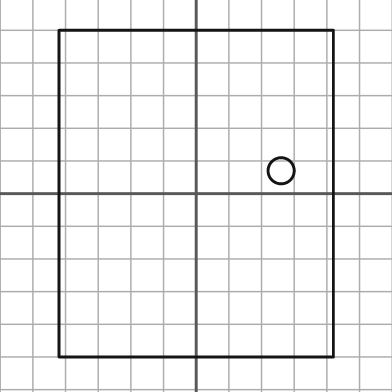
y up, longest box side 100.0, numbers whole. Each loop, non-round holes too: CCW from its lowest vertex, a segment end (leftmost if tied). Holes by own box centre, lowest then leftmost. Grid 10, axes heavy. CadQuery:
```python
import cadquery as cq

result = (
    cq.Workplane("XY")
    .moveTo(-42.0, -50.0)
    .lineTo(42.0, -50.0)
    .lineTo(42.0, 50.0)
    .lineTo(-42.0, 50.0)
    .close()
    .moveTo(26.0, 7.0)
    .circle(4.0)
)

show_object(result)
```